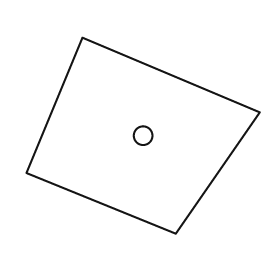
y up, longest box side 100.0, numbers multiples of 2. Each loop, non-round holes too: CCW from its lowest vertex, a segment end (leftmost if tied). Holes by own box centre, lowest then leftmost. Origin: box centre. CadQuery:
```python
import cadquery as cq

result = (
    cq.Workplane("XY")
    .moveTo(14.0, -42.0)
    .lineTo(50.0, 10.0)
    .lineTo(-26.0, 42.0)
    .lineTo(-50.0, -16.0)
    .close()
    .moveTo(0.0, 0.0)
    .circle(4.0)
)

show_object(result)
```